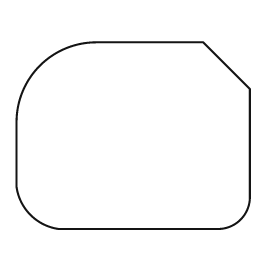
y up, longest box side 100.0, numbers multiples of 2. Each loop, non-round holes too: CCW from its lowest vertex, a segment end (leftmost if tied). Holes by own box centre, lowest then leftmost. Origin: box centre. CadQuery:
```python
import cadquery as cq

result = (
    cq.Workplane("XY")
    .moveTo(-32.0, -40.0)
    .lineTo(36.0, -40.0)
    .threePointArc((46.0, -36.0), (50.0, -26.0))
    .lineTo(50.0, 20.0)
    .lineTo(30.0, 40.0)
    .lineTo(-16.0, 40.0)
    .threePointArc((-40.0, 30.0), (-50.0, 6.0))
    .lineTo(-50.0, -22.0)
    .threePointArc((-44.0, -34.0), (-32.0, -40.0))
    .close()
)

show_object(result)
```